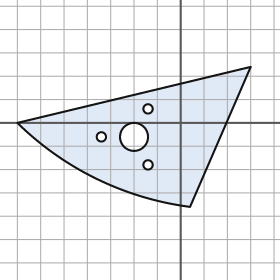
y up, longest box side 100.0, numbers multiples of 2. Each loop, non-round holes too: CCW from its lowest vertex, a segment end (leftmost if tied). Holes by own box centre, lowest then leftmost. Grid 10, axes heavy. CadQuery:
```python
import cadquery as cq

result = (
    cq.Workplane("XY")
    .moveTo(4.0, -36.0)
    .lineTo(30.0, 24.0)
    .lineTo(-70.0, 0.0)
    .threePointArc((-36.0, -24.0), (4.0, -36.0))
    .close()
    .moveTo(-14.0, -18.0)
    .circle(2.0)
    .moveTo(-34.0, -6.0)
    .circle(2.0)
    .moveTo(-20.0, -6.0)
    .circle(6.0)
    .moveTo(-14.0, 6.0)
    .circle(2.0)
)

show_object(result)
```